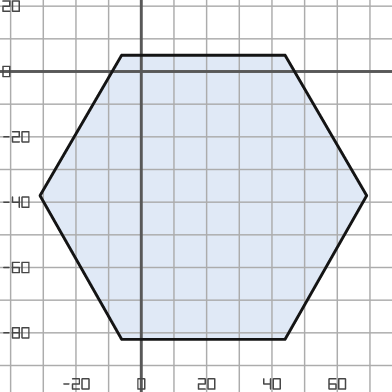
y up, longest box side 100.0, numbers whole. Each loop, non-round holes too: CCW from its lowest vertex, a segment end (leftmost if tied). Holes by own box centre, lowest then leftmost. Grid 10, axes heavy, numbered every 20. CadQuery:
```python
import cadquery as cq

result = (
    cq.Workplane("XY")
    .moveTo(-6.0, -82.0)
    .lineTo(44.0, -82.0)
    .lineTo(69.0, -38.0)
    .lineTo(44.0, 5.0)
    .lineTo(-6.0, 5.0)
    .lineTo(-31.0, -38.0)
    .close()
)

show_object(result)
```